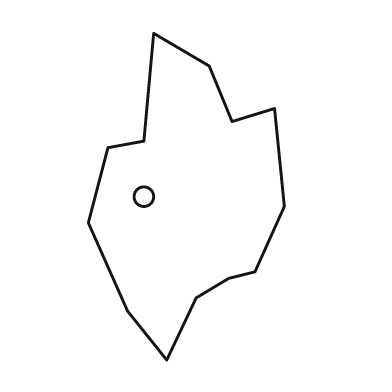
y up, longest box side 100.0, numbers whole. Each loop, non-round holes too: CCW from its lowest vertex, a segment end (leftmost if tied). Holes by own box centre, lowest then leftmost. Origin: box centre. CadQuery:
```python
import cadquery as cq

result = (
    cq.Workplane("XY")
    .moveTo(-6.0, -50.0)
    .lineTo(3.0, -31.0)
    .lineTo(13.0, -25.0)
    .lineTo(21.0, -23.0)
    .lineTo(30.0, -3.0)
    .lineTo(27.0, 27.0)
    .lineTo(14.0, 23.0)
    .lineTo(7.0, 40.0)
    .lineTo(-10.0, 50.0)
    .lineTo(-13.0, 17.0)
    .lineTo(-24.0, 15.0)
    .lineTo(-30.0, -8.0)
    .lineTo(-18.0, -35.0)
    .close()
    .moveTo(-13.0, 0.0)
    .circle(3.0)
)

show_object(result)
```